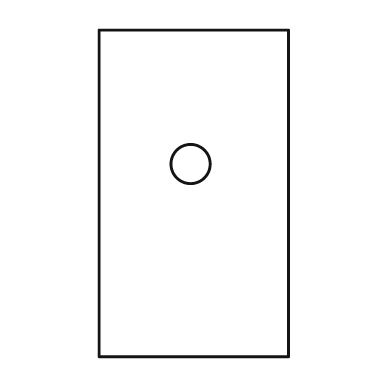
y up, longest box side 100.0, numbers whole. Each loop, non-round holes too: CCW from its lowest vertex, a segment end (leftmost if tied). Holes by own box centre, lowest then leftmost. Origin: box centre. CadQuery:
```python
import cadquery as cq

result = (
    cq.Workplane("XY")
    .moveTo(-29.0, -50.0)
    .lineTo(29.0, -50.0)
    .lineTo(29.0, 50.0)
    .lineTo(-29.0, 50.0)
    .close()
    .moveTo(-1.0, 9.0)
    .circle(6.0)
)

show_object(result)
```